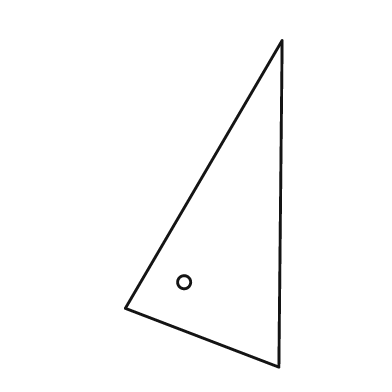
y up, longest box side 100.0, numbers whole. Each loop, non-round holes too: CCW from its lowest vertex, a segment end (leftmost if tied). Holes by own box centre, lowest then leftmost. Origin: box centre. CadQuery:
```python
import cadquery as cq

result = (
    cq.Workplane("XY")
    .moveTo(23.0, -50.0)
    .lineTo(24.0, 50.0)
    .lineTo(-24.0, -32.0)
    .close()
    .moveTo(-6.0, -24.0)
    .circle(2.0)
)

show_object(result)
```